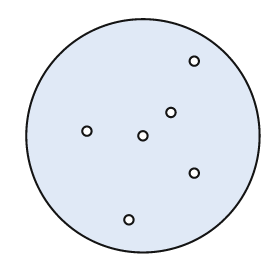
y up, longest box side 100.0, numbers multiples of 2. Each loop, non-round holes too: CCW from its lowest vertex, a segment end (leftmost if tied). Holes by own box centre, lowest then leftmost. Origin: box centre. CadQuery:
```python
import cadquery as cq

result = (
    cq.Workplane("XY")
    .moveTo(0.0, 0.0)
    .circle(50.0)
    .moveTo(-6.0, -36.0)
    .circle(2.0)
    .moveTo(22.0, -16.0)
    .circle(2.0)
    .moveTo(0.0, 0.0)
    .circle(2.0)
    .moveTo(-24.0, 2.0)
    .circle(2.0)
    .moveTo(12.0, 10.0)
    .circle(2.0)
    .moveTo(22.0, 32.0)
    .circle(2.0)
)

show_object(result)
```